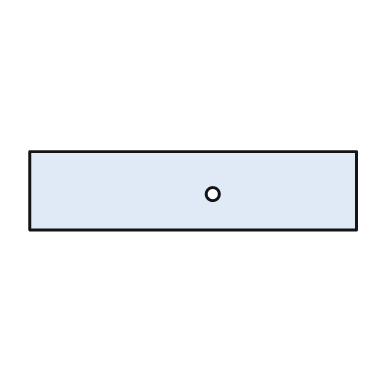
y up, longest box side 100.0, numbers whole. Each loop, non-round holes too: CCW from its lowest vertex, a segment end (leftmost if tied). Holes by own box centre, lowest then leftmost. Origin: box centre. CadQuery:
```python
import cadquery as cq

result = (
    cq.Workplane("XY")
    .moveTo(-50.0, -12.0)
    .lineTo(50.0, -12.0)
    .lineTo(50.0, 12.0)
    .lineTo(-50.0, 12.0)
    .close()
    .moveTo(6.0, -1.0)
    .circle(2.0)
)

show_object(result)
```